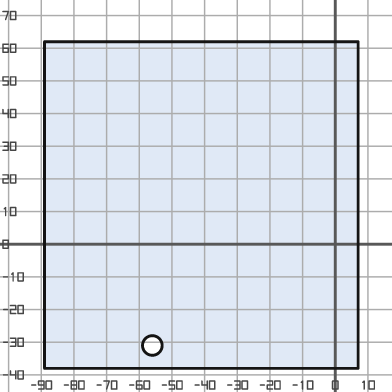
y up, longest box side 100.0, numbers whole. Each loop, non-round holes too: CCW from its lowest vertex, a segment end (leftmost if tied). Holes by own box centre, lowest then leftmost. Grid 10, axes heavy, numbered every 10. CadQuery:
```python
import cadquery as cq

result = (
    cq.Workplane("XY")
    .moveTo(-89.0, -38.0)
    .lineTo(7.0, -38.0)
    .lineTo(7.0, 62.0)
    .lineTo(-89.0, 62.0)
    .close()
    .moveTo(-56.0, -31.0)
    .circle(3.0)
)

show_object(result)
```